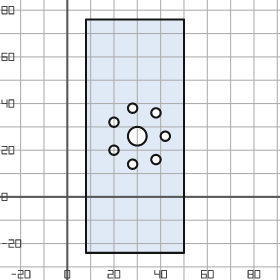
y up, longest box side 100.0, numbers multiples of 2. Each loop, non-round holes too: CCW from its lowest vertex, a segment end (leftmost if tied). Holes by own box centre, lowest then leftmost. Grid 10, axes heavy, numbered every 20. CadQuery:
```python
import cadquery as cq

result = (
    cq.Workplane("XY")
    .moveTo(8.0, -24.0)
    .lineTo(50.0, -24.0)
    .lineTo(50.0, 76.0)
    .lineTo(8.0, 76.0)
    .close()
    .moveTo(28.0, 14.0)
    .circle(2.0)
    .moveTo(38.0, 16.0)
    .circle(2.0)
    .moveTo(20.0, 20.0)
    .circle(2.0)
    .moveTo(30.0, 26.0)
    .circle(4.0)
    .moveTo(42.0, 26.0)
    .circle(2.0)
    .moveTo(20.0, 32.0)
    .circle(2.0)
    .moveTo(38.0, 36.0)
    .circle(2.0)
    .moveTo(28.0, 38.0)
    .circle(2.0)
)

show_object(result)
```